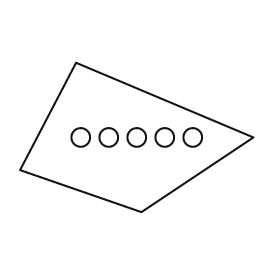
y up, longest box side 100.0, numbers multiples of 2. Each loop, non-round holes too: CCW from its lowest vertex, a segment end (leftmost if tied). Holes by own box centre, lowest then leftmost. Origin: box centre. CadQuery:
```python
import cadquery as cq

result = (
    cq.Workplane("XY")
    .moveTo(2.0, -32.0)
    .lineTo(50.0, 0.0)
    .lineTo(-26.0, 32.0)
    .lineTo(-50.0, -14.0)
    .close()
    .moveTo(-24.0, 0.0)
    .circle(4.0)
    .moveTo(-12.0, 0.0)
    .circle(4.0)
    .moveTo(0.0, 0.0)
    .circle(4.0)
    .moveTo(12.0, 0.0)
    .circle(4.0)
    .moveTo(24.0, 0.0)
    .circle(4.0)
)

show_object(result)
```